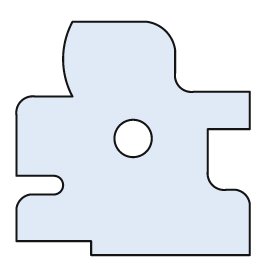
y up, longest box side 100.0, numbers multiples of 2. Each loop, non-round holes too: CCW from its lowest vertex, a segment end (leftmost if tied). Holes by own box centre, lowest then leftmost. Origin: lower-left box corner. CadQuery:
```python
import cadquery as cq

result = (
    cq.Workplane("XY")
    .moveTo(32.0, 0.0)
    .lineTo(100.0, 0.0)
    .lineTo(100.0, 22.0)
    .threePointArc((98.0, 26.0), (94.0, 28.0))
    .lineTo(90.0, 28.0)
    .threePointArc((84.0, 30.0), (82.0, 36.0))
    .lineTo(82.0, 54.0)
    .lineTo(100.0, 54.0)
    .lineTo(100.0, 70.0)
    .lineTo(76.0, 70.0)
    .threePointArc((70.0, 72.0), (68.0, 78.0))
    .lineTo(68.0, 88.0)
    .threePointArc((64.0, 96.0), (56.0, 100.0))
    .lineTo(24.0, 100.0)
    .threePointArc((20.0, 84.0), (24.0, 68.0))
    .lineTo(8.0, 68.0)
    .threePointArc((2.0, 66.0), (0.0, 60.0))
    .lineTo(0.0, 34.0)
    .lineTo(16.0, 34.0)
    .threePointArc((20.0, 30.0), (16.0, 26.0))
    .lineTo(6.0, 26.0)
    .threePointArc((2.0, 24.0), (0.0, 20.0))
    .lineTo(0.0, 6.0)
    .lineTo(32.0, 6.0)
    .close()
    .moveTo(50.0, 50.0)
    .circle(8.0)
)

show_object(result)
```